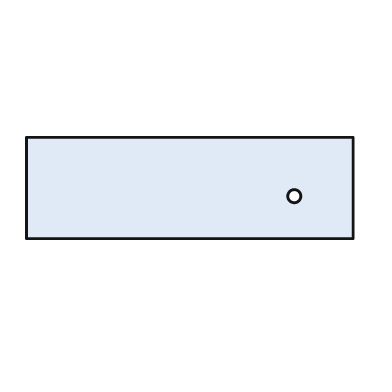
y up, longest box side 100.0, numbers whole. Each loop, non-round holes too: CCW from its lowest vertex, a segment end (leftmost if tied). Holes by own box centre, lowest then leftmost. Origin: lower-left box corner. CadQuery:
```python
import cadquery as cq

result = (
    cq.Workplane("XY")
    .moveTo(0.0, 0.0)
    .lineTo(100.0, 0.0)
    .lineTo(100.0, 31.0)
    .lineTo(0.0, 31.0)
    .close()
    .moveTo(82.0, 13.0)
    .circle(2.0)
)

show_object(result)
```